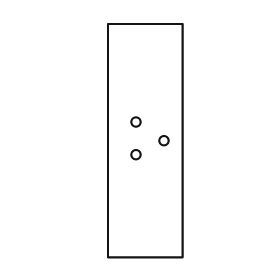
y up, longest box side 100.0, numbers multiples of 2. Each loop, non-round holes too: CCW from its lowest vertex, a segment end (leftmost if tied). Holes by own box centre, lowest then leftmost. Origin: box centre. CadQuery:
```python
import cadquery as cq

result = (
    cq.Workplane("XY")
    .moveTo(-16.0, -50.0)
    .lineTo(16.0, -50.0)
    .lineTo(16.0, 50.0)
    .lineTo(-16.0, 50.0)
    .close()
    .moveTo(-4.0, -6.0)
    .circle(2.0)
    .moveTo(8.0, 0.0)
    .circle(2.0)
    .moveTo(-4.0, 8.0)
    .circle(2.0)
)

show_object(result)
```